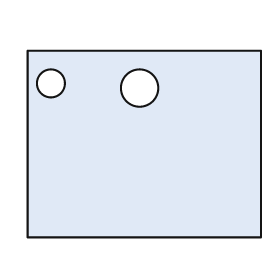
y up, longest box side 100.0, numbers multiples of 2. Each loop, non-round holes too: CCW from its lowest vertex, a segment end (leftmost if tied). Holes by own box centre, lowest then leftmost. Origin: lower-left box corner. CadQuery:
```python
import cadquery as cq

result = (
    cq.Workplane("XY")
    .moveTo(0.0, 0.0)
    .lineTo(100.0, 0.0)
    .lineTo(100.0, 80.0)
    .lineTo(0.0, 80.0)
    .close()
    .moveTo(48.0, 64.0)
    .circle(8.0)
    .moveTo(10.0, 66.0)
    .circle(6.0)
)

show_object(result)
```